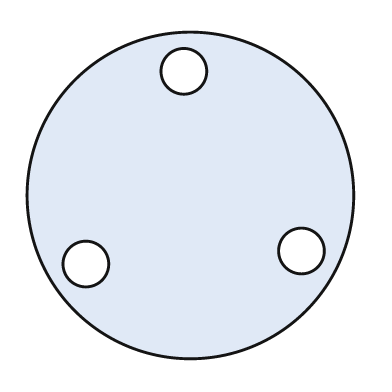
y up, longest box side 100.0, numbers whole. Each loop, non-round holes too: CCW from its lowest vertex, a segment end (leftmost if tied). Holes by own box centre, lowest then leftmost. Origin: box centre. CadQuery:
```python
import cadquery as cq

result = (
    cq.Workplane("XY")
    .moveTo(0.0, 0.0)
    .circle(50.0)
    .moveTo(-32.0, -21.0)
    .circle(7.0)
    .moveTo(34.0, -17.0)
    .circle(7.0)
    .moveTo(-2.0, 38.0)
    .circle(7.0)
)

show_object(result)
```